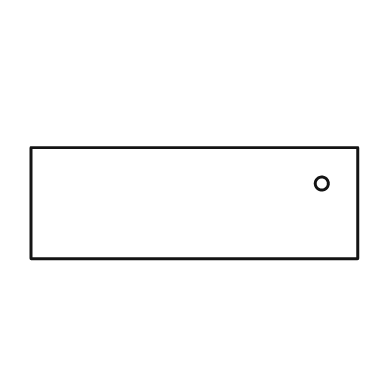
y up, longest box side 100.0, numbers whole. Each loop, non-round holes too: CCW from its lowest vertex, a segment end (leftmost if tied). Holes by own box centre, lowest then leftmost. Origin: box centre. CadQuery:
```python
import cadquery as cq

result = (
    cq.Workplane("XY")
    .moveTo(-50.0, -17.0)
    .lineTo(50.0, -17.0)
    .lineTo(50.0, 17.0)
    .lineTo(-50.0, 17.0)
    .close()
    .moveTo(39.0, 6.0)
    .circle(2.0)
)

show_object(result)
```